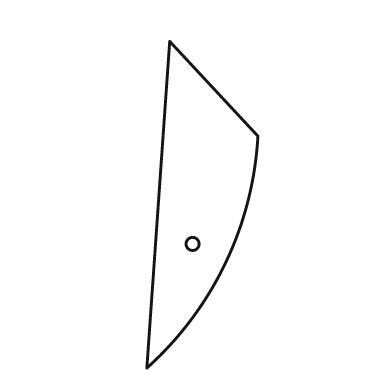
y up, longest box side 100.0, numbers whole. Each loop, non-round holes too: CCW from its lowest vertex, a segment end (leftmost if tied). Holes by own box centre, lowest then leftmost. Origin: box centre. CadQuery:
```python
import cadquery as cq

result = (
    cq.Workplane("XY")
    .moveTo(-17.0, -50.0)
    .threePointArc((7.0, -18.0), (17.0, 21.0))
    .lineTo(-10.0, 50.0)
    .close()
    .moveTo(-3.0, -12.0)
    .circle(2.0)
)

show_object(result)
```